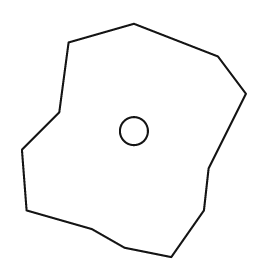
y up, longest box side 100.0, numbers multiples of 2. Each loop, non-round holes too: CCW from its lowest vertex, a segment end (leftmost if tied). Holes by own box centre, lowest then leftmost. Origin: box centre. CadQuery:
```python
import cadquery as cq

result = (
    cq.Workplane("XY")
    .moveTo(16.0, -50.0)
    .lineTo(30.0, -30.0)
    .lineTo(32.0, -12.0)
    .lineTo(48.0, 20.0)
    .lineTo(36.0, 36.0)
    .lineTo(0.0, 50.0)
    .lineTo(-28.0, 42.0)
    .lineTo(-32.0, 12.0)
    .lineTo(-48.0, -4.0)
    .lineTo(-46.0, -30.0)
    .lineTo(-18.0, -38.0)
    .lineTo(-4.0, -46.0)
    .close()
    .moveTo(0.0, 4.0)
    .circle(6.0)
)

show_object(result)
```